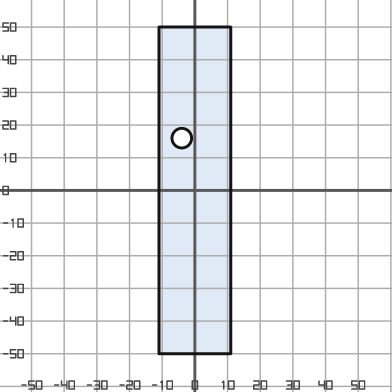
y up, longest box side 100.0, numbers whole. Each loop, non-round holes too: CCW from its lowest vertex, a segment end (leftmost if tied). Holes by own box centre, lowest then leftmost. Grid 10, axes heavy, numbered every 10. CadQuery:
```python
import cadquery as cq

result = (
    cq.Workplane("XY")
    .moveTo(-11.0, -50.0)
    .lineTo(11.0, -50.0)
    .lineTo(11.0, 50.0)
    .lineTo(-11.0, 50.0)
    .close()
    .moveTo(-4.0, 16.0)
    .circle(3.0)
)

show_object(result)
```